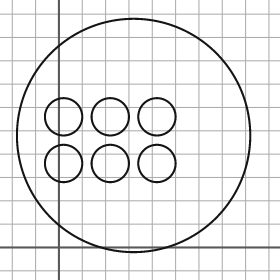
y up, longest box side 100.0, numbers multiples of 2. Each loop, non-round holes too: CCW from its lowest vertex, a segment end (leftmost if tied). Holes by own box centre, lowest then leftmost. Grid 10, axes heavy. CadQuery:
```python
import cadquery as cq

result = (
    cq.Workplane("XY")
    .moveTo(32.0, 48.0)
    .circle(50.0)
    .moveTo(2.0, 36.0)
    .circle(8.0)
    .moveTo(22.0, 36.0)
    .circle(8.0)
    .moveTo(42.0, 36.0)
    .circle(8.0)
    .moveTo(2.0, 56.0)
    .circle(8.0)
    .moveTo(22.0, 56.0)
    .circle(8.0)
    .moveTo(42.0, 56.0)
    .circle(8.0)
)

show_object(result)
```